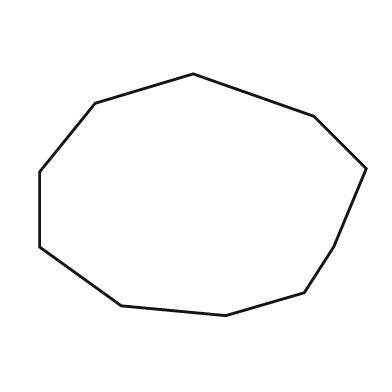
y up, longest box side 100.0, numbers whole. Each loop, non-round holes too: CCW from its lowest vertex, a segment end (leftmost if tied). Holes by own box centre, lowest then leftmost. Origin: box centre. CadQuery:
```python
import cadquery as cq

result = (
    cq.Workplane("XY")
    .moveTo(7.0, -37.0)
    .lineTo(31.0, -30.0)
    .lineTo(40.0, -16.0)
    .lineTo(50.0, 8.0)
    .lineTo(34.0, 24.0)
    .lineTo(-3.0, 37.0)
    .lineTo(-33.0, 28.0)
    .lineTo(-50.0, 7.0)
    .lineTo(-50.0, -16.0)
    .lineTo(-25.0, -34.0)
    .close()
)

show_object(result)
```